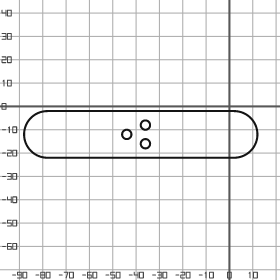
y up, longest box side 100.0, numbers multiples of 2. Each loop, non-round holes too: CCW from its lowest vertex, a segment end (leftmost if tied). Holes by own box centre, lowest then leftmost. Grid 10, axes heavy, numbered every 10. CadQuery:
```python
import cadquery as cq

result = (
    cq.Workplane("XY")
    .moveTo(-78.0, -22.0)
    .lineTo(2.0, -22.0)
    .threePointArc((12.0, -12.0), (2.0, -2.0))
    .lineTo(-78.0, -2.0)
    .threePointArc((-88.0, -12.0), (-78.0, -22.0))
    .close()
    .moveTo(-36.0, -16.0)
    .circle(2.0)
    .moveTo(-44.0, -12.0)
    .circle(2.0)
    .moveTo(-36.0, -8.0)
    .circle(2.0)
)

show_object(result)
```